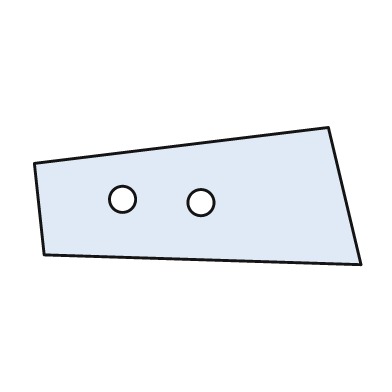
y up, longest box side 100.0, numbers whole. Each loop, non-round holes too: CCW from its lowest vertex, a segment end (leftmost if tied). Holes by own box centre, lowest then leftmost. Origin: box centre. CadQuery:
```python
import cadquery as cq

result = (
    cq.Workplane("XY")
    .moveTo(50.0, -21.0)
    .lineTo(40.0, 21.0)
    .lineTo(-50.0, 10.0)
    .lineTo(-47.0, -18.0)
    .close()
    .moveTo(1.0, -2.0)
    .circle(4.0)
    .moveTo(-23.0, -1.0)
    .circle(4.0)
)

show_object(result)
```